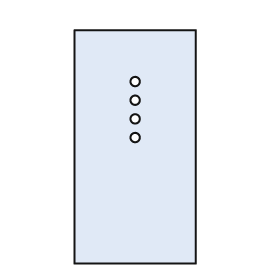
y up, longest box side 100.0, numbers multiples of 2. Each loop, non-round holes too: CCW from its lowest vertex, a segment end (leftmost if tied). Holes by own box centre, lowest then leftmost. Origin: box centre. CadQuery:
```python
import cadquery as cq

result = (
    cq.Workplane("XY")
    .moveTo(-26.0, -50.0)
    .lineTo(26.0, -50.0)
    .lineTo(26.0, 50.0)
    .lineTo(-26.0, 50.0)
    .close()
    .moveTo(0.0, 4.0)
    .circle(2.0)
    .moveTo(0.0, 12.0)
    .circle(2.0)
    .moveTo(0.0, 20.0)
    .circle(2.0)
    .moveTo(0.0, 28.0)
    .circle(2.0)
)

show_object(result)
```